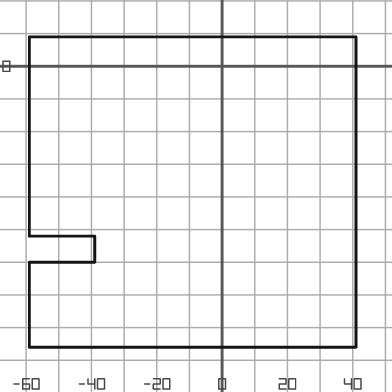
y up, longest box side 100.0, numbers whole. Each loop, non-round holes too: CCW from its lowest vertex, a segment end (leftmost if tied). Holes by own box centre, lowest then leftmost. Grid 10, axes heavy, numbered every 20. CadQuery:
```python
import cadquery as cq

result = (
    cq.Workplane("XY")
    .moveTo(-59.0, -86.0)
    .lineTo(41.0, -86.0)
    .lineTo(41.0, 9.0)
    .lineTo(-59.0, 9.0)
    .lineTo(-59.0, -52.0)
    .lineTo(-39.0, -52.0)
    .lineTo(-39.0, -60.0)
    .lineTo(-59.0, -60.0)
    .close()
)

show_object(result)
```